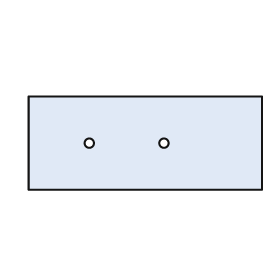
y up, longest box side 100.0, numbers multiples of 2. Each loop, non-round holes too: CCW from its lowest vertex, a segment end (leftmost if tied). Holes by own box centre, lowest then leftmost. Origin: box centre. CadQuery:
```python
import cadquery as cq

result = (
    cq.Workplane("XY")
    .moveTo(-50.0, -20.0)
    .lineTo(50.0, -20.0)
    .lineTo(50.0, 20.0)
    .lineTo(-50.0, 20.0)
    .close()
    .moveTo(-24.0, 0.0)
    .circle(2.0)
    .moveTo(8.0, 0.0)
    .circle(2.0)
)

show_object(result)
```